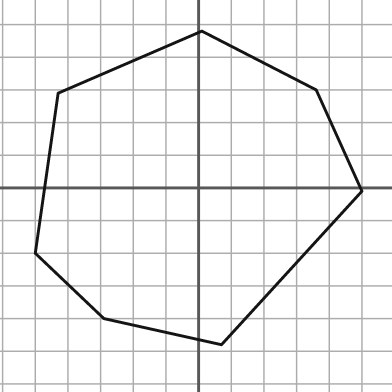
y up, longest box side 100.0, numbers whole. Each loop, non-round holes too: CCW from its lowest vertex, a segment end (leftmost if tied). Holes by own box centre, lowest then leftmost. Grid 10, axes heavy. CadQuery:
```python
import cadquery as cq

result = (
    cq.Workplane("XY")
    .moveTo(7.0, -48.0)
    .lineTo(50.0, -1.0)
    .lineTo(36.0, 30.0)
    .lineTo(1.0, 48.0)
    .lineTo(-43.0, 29.0)
    .lineTo(-50.0, -20.0)
    .lineTo(-29.0, -40.0)
    .close()
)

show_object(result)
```